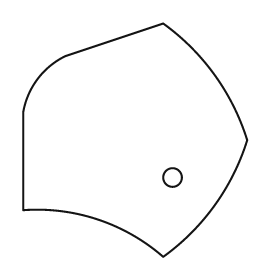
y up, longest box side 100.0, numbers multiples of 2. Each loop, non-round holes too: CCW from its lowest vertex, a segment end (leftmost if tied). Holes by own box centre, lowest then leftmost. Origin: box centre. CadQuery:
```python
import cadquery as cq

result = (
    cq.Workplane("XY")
    .moveTo(12.0, -50.0)
    .threePointArc((34.0, -28.0), (48.0, 0.0))
    .threePointArc((34.0, 28.0), (12.0, 50.0))
    .lineTo(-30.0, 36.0)
    .threePointArc((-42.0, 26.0), (-48.0, 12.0))
    .lineTo(-48.0, -30.0)
    .threePointArc((-16.0, -34.0), (12.0, -50.0))
    .close()
    .moveTo(16.0, -16.0)
    .circle(4.0)
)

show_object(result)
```